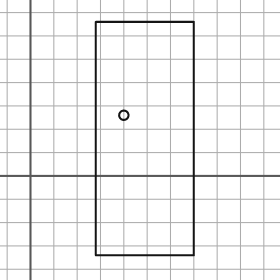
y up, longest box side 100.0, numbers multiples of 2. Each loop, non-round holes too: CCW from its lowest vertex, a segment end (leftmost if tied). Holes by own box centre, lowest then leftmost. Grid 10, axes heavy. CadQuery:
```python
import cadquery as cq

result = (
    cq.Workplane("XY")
    .moveTo(28.0, -34.0)
    .lineTo(70.0, -34.0)
    .lineTo(70.0, 66.0)
    .lineTo(28.0, 66.0)
    .close()
    .moveTo(40.0, 26.0)
    .circle(2.0)
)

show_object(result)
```